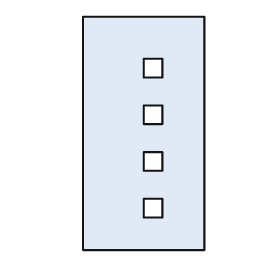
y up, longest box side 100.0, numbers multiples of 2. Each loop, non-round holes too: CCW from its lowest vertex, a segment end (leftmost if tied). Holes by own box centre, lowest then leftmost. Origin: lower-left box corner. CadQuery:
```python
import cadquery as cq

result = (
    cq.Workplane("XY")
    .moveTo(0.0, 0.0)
    .lineTo(52.0, 0.0)
    .lineTo(52.0, 100.0)
    .lineTo(0.0, 100.0)
    .close()
    .moveTo(26.0, 14.0)
    .lineTo(34.0, 14.0)
    .lineTo(34.0, 22.0)
    .lineTo(26.0, 22.0)
    .close()
    .moveTo(26.0, 34.0)
    .lineTo(34.0, 34.0)
    .lineTo(34.0, 42.0)
    .lineTo(26.0, 42.0)
    .close()
    .moveTo(26.0, 54.0)
    .lineTo(34.0, 54.0)
    .lineTo(34.0, 62.0)
    .lineTo(26.0, 62.0)
    .close()
    .moveTo(26.0, 74.0)
    .lineTo(34.0, 74.0)
    .lineTo(34.0, 82.0)
    .lineTo(26.0, 82.0)
    .close()
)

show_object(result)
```